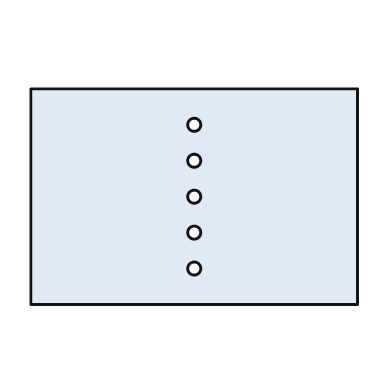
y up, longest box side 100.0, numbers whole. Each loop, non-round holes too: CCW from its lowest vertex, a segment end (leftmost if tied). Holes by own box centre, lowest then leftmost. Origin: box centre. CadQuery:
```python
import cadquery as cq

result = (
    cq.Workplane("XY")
    .moveTo(-50.0, -33.0)
    .lineTo(50.0, -33.0)
    .lineTo(50.0, 33.0)
    .lineTo(-50.0, 33.0)
    .close()
    .moveTo(0.0, -22.0)
    .circle(2.0)
    .moveTo(0.0, -11.0)
    .circle(2.0)
    .moveTo(0.0, 0.0)
    .circle(2.0)
    .moveTo(0.0, 11.0)
    .circle(2.0)
    .moveTo(0.0, 22.0)
    .circle(2.0)
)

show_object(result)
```